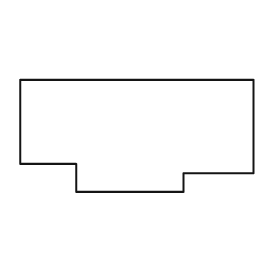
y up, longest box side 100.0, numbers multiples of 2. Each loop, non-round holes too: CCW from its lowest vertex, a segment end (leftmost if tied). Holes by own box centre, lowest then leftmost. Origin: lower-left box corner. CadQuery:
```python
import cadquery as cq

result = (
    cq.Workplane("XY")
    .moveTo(24.0, 0.0)
    .lineTo(70.0, 0.0)
    .lineTo(70.0, 8.0)
    .lineTo(100.0, 8.0)
    .lineTo(100.0, 48.0)
    .lineTo(0.0, 48.0)
    .lineTo(0.0, 12.0)
    .lineTo(24.0, 12.0)
    .close()
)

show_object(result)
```